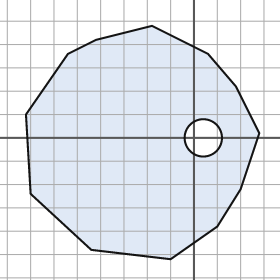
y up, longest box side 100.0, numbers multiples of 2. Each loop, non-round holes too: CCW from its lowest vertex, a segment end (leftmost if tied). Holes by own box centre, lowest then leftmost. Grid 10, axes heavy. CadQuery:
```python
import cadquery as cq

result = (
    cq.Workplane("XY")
    .moveTo(-10.0, -52.0)
    .lineTo(10.0, -38.0)
    .lineTo(20.0, -22.0)
    .lineTo(28.0, 2.0)
    .lineTo(18.0, 22.0)
    .lineTo(6.0, 36.0)
    .lineTo(-18.0, 48.0)
    .lineTo(-42.0, 42.0)
    .lineTo(-54.0, 36.0)
    .lineTo(-72.0, 10.0)
    .lineTo(-70.0, -24.0)
    .lineTo(-44.0, -48.0)
    .close()
    .moveTo(4.0, 0.0)
    .circle(8.0)
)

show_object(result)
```